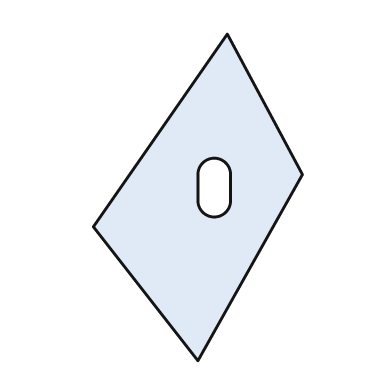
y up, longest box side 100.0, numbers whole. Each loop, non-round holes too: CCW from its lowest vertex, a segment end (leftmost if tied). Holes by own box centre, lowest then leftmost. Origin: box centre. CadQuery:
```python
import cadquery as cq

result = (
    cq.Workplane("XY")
    .moveTo(0.0, -50.0)
    .lineTo(32.0, 7.0)
    .lineTo(9.0, 50.0)
    .lineTo(-32.0, -9.0)
    .close()
    .moveTo(0.0, -1.0)
    .threePointArc((5.0, -6.0), (10.0, -1.0))
    .lineTo(10.0, 7.0)
    .threePointArc((5.0, 12.0), (0.0, 7.0))
    .close()
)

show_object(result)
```